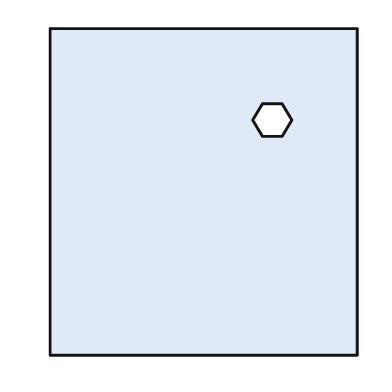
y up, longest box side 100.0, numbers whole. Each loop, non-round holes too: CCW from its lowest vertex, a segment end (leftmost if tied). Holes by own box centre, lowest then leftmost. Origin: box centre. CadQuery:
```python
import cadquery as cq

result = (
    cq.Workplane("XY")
    .moveTo(-47.0, -50.0)
    .lineTo(47.0, -50.0)
    .lineTo(47.0, 50.0)
    .lineTo(-47.0, 50.0)
    .close()
    .moveTo(18.0, 17.0)
    .lineTo(24.0, 17.0)
    .lineTo(27.0, 22.0)
    .lineTo(24.0, 27.0)
    .lineTo(18.0, 27.0)
    .lineTo(15.0, 22.0)
    .close()
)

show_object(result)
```